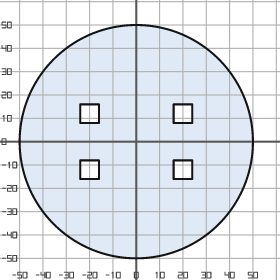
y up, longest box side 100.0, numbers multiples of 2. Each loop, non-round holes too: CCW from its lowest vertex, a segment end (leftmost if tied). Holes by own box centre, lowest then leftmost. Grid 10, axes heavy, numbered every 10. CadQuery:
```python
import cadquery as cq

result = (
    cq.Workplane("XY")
    .moveTo(0.0, 0.0)
    .circle(50.0)
    .moveTo(-24.0, -16.0)
    .lineTo(-16.0, -16.0)
    .lineTo(-16.0, -8.0)
    .lineTo(-24.0, -8.0)
    .close()
    .moveTo(16.0, -16.0)
    .lineTo(24.0, -16.0)
    .lineTo(24.0, -8.0)
    .lineTo(16.0, -8.0)
    .close()
    .moveTo(-24.0, 8.0)
    .lineTo(-16.0, 8.0)
    .lineTo(-16.0, 16.0)
    .lineTo(-24.0, 16.0)
    .close()
    .moveTo(16.0, 8.0)
    .lineTo(24.0, 8.0)
    .lineTo(24.0, 16.0)
    .lineTo(16.0, 16.0)
    .close()
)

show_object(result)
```